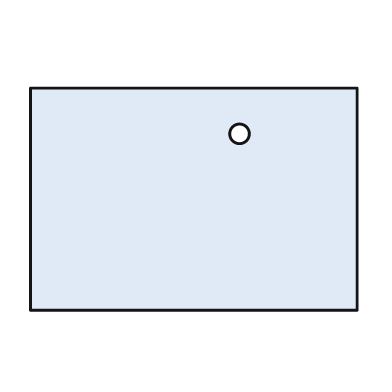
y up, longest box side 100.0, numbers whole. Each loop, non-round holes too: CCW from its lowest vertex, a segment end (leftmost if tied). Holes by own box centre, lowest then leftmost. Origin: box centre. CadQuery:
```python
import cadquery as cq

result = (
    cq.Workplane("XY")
    .moveTo(-50.0, -34.0)
    .lineTo(50.0, -34.0)
    .lineTo(50.0, 34.0)
    .lineTo(-50.0, 34.0)
    .close()
    .moveTo(14.0, 20.0)
    .circle(3.0)
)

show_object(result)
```